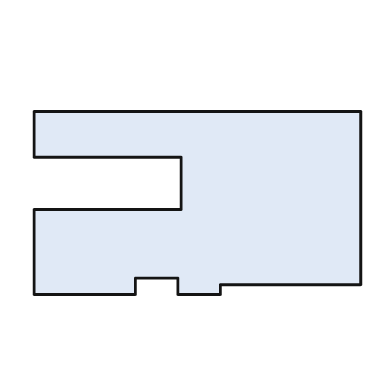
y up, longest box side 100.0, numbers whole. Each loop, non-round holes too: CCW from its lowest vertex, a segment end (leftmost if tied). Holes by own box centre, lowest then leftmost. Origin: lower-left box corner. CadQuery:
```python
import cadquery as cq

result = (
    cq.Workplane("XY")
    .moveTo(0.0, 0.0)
    .lineTo(31.0, 0.0)
    .lineTo(31.0, 5.0)
    .lineTo(44.0, 5.0)
    .lineTo(44.0, 0.0)
    .lineTo(57.0, 0.0)
    .lineTo(57.0, 3.0)
    .lineTo(100.0, 3.0)
    .lineTo(100.0, 56.0)
    .lineTo(0.0, 56.0)
    .lineTo(0.0, 42.0)
    .lineTo(45.0, 42.0)
    .lineTo(45.0, 26.0)
    .lineTo(0.0, 26.0)
    .close()
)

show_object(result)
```